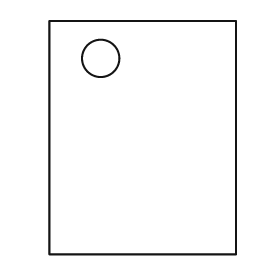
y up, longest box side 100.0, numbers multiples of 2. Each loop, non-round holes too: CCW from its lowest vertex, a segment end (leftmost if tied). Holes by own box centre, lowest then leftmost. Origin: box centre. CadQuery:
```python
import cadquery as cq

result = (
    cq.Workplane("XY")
    .moveTo(-40.0, -50.0)
    .lineTo(40.0, -50.0)
    .lineTo(40.0, 50.0)
    .lineTo(-40.0, 50.0)
    .close()
    .moveTo(-18.0, 34.0)
    .circle(8.0)
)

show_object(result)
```